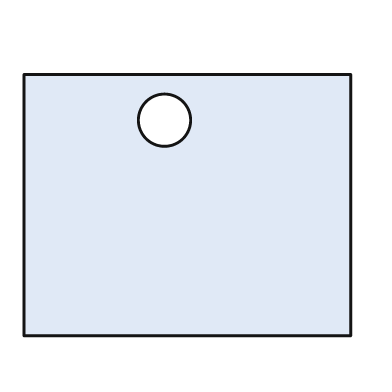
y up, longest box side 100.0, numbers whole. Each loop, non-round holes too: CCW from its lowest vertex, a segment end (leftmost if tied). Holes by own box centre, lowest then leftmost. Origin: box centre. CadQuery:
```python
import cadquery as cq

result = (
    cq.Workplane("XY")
    .moveTo(-50.0, -40.0)
    .lineTo(50.0, -40.0)
    .lineTo(50.0, 40.0)
    .lineTo(-50.0, 40.0)
    .close()
    .moveTo(-7.0, 26.0)
    .circle(8.0)
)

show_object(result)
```